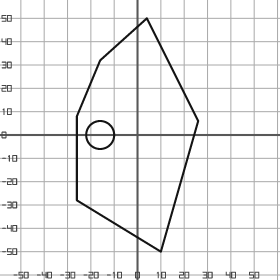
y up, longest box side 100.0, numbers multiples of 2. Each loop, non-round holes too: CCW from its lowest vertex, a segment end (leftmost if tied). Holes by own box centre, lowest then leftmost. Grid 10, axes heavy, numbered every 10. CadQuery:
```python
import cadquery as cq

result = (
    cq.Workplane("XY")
    .moveTo(10.0, -50.0)
    .lineTo(26.0, 6.0)
    .lineTo(4.0, 50.0)
    .lineTo(-16.0, 32.0)
    .lineTo(-26.0, 8.0)
    .lineTo(-26.0, -28.0)
    .close()
    .moveTo(-16.0, 0.0)
    .circle(6.0)
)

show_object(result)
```